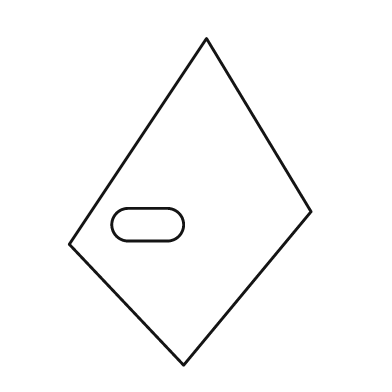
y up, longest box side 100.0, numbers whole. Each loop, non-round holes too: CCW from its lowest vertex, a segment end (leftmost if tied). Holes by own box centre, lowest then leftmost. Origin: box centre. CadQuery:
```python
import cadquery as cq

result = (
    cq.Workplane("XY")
    .moveTo(-2.0, -50.0)
    .lineTo(37.0, -3.0)
    .lineTo(5.0, 50.0)
    .lineTo(-37.0, -13.0)
    .close()
    .moveTo(-19.0, -12.0)
    .lineTo(-7.0, -12.0)
    .threePointArc((-2.0, -7.0), (-7.0, -2.0))
    .lineTo(-19.0, -2.0)
    .threePointArc((-24.0, -7.0), (-19.0, -12.0))
    .close()
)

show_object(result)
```